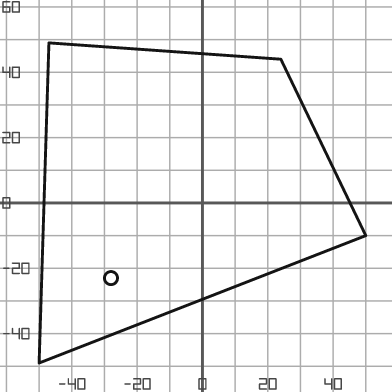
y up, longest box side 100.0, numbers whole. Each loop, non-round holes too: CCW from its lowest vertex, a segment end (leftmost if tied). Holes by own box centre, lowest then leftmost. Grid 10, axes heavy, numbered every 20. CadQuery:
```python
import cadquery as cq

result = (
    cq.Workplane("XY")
    .moveTo(-50.0, -49.0)
    .lineTo(50.0, -10.0)
    .lineTo(24.0, 44.0)
    .lineTo(-47.0, 49.0)
    .close()
    .moveTo(-28.0, -23.0)
    .circle(2.0)
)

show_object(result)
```